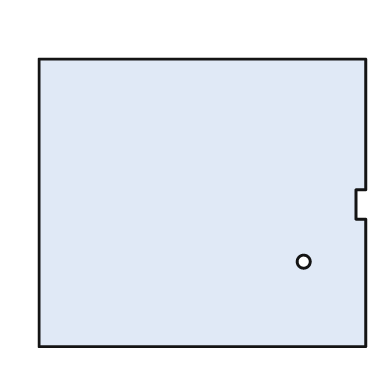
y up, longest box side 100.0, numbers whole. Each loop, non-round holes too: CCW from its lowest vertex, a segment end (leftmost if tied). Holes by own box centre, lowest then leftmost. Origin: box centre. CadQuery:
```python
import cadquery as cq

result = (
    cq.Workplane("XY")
    .moveTo(-50.0, -44.0)
    .lineTo(50.0, -44.0)
    .lineTo(50.0, -5.0)
    .lineTo(47.0, -5.0)
    .lineTo(47.0, 4.0)
    .lineTo(50.0, 4.0)
    .lineTo(50.0, 44.0)
    .lineTo(-50.0, 44.0)
    .close()
    .moveTo(31.0, -18.0)
    .circle(2.0)
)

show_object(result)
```